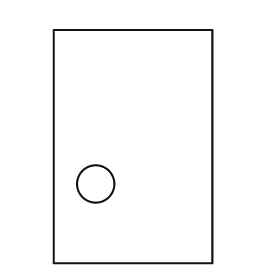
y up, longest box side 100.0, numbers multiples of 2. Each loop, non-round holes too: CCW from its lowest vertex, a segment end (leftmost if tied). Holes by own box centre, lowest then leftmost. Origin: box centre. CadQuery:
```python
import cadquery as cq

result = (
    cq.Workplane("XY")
    .moveTo(-34.0, -50.0)
    .lineTo(34.0, -50.0)
    .lineTo(34.0, 50.0)
    .lineTo(-34.0, 50.0)
    .close()
    .moveTo(-16.0, -16.0)
    .circle(8.0)
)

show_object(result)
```